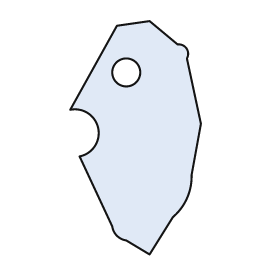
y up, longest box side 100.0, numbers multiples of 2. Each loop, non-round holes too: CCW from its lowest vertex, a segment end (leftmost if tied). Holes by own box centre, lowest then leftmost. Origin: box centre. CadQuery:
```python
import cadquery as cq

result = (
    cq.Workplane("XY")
    .moveTo(6.0, -50.0)
    .lineTo(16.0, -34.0)
    .threePointArc((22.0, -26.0), (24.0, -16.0))
    .lineTo(28.0, 6.0)
    .lineTo(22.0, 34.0)
    .threePointArc((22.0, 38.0), (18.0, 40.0))
    .lineTo(6.0, 50.0)
    .lineTo(-8.0, 48.0)
    .lineTo(-28.0, 12.0)
    .threePointArc((-16.0, 4.0), (-24.0, -8.0))
    .lineTo(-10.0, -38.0)
    .threePointArc((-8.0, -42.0), (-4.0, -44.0))
    .close()
    .moveTo(-4.0, 28.0)
    .circle(6.0)
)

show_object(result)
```